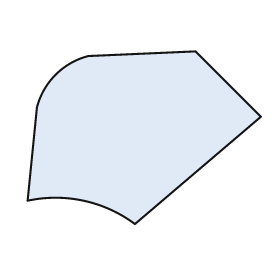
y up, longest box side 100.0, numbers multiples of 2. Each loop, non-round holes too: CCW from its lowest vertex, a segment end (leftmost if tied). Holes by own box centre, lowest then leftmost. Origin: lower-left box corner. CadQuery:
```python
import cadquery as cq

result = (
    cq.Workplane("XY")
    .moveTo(46.0, 0.0)
    .lineTo(100.0, 46.0)
    .lineTo(72.0, 74.0)
    .lineTo(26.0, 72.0)
    .threePointArc((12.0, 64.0), (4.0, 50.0))
    .lineTo(0.0, 10.0)
    .threePointArc((24.0, 10.0), (46.0, 0.0))
    .close()
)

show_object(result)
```